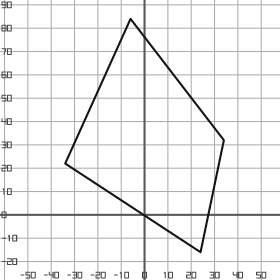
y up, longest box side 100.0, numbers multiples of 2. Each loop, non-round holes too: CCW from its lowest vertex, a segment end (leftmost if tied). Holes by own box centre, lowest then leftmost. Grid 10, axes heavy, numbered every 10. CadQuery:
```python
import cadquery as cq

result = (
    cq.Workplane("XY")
    .moveTo(24.0, -16.0)
    .lineTo(34.0, 32.0)
    .lineTo(-6.0, 84.0)
    .lineTo(-34.0, 22.0)
    .close()
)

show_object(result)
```